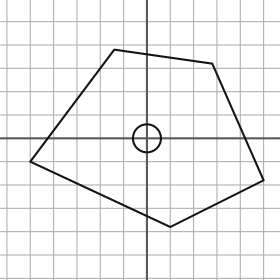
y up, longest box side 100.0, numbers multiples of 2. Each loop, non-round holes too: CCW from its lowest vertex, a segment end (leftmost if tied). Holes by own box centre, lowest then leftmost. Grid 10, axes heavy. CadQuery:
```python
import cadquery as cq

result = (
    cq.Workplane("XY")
    .moveTo(10.0, -38.0)
    .lineTo(50.0, -18.0)
    .lineTo(28.0, 32.0)
    .lineTo(-14.0, 38.0)
    .lineTo(-50.0, -10.0)
    .close()
    .moveTo(0.0, 0.0)
    .circle(6.0)
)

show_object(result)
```